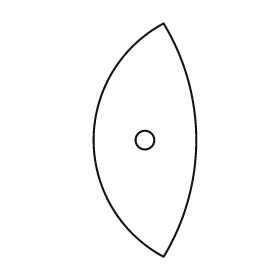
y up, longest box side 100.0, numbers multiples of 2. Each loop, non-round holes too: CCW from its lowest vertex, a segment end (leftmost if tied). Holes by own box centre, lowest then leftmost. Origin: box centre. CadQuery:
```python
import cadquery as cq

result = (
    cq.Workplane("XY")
    .moveTo(8.0, -50.0)
    .threePointArc((22.0, 0.0), (8.0, 50.0))
    .threePointArc((-22.0, 0.0), (8.0, -50.0))
    .close()
    .moveTo(0.0, 0.0)
    .circle(4.0)
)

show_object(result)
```